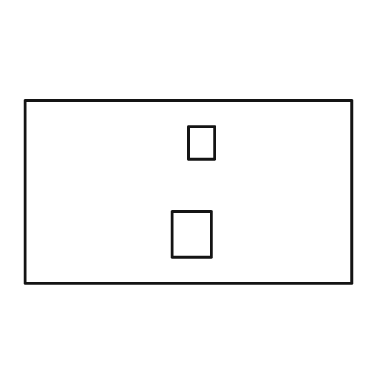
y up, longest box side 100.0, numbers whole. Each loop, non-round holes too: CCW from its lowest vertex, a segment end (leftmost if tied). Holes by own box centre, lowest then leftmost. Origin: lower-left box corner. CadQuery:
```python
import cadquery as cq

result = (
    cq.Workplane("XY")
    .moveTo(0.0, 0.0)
    .lineTo(100.0, 0.0)
    .lineTo(100.0, 56.0)
    .lineTo(0.0, 56.0)
    .close()
    .moveTo(45.0, 8.0)
    .lineTo(57.0, 8.0)
    .lineTo(57.0, 22.0)
    .lineTo(45.0, 22.0)
    .close()
    .moveTo(50.0, 38.0)
    .lineTo(58.0, 38.0)
    .lineTo(58.0, 48.0)
    .lineTo(50.0, 48.0)
    .close()
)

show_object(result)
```